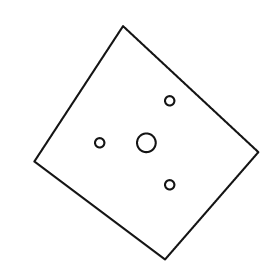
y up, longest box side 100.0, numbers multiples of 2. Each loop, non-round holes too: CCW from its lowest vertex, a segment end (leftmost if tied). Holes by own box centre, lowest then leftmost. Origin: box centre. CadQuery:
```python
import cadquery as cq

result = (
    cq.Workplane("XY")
    .moveTo(8.0, -50.0)
    .lineTo(48.0, -4.0)
    .lineTo(-10.0, 50.0)
    .lineTo(-48.0, -8.0)
    .close()
    .moveTo(10.0, -18.0)
    .circle(2.0)
    .moveTo(-20.0, 0.0)
    .circle(2.0)
    .moveTo(0.0, 0.0)
    .circle(4.0)
    .moveTo(10.0, 18.0)
    .circle(2.0)
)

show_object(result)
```